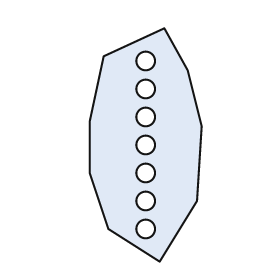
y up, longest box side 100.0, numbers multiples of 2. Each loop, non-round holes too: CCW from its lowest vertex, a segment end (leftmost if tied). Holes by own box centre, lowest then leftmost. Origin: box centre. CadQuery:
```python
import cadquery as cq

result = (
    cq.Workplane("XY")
    .moveTo(6.0, -50.0)
    .lineTo(22.0, -24.0)
    .lineTo(24.0, 8.0)
    .lineTo(18.0, 32.0)
    .lineTo(8.0, 50.0)
    .lineTo(-18.0, 38.0)
    .lineTo(-24.0, 10.0)
    .lineTo(-24.0, -12.0)
    .lineTo(-16.0, -36.0)
    .close()
    .moveTo(0.0, -36.0)
    .circle(4.0)
    .moveTo(0.0, -24.0)
    .circle(4.0)
    .moveTo(0.0, -12.0)
    .circle(4.0)
    .moveTo(0.0, 0.0)
    .circle(4.0)
    .moveTo(0.0, 12.0)
    .circle(4.0)
    .moveTo(0.0, 24.0)
    .circle(4.0)
    .moveTo(0.0, 36.0)
    .circle(4.0)
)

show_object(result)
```